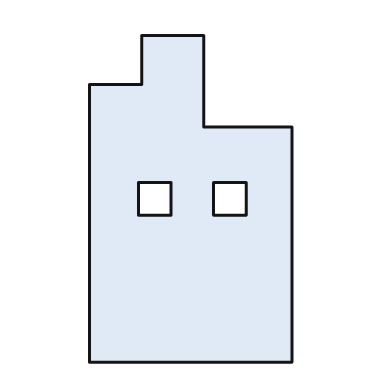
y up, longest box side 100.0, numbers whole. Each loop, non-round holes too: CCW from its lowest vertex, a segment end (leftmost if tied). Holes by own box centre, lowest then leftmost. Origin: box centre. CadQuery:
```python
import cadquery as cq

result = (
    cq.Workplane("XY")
    .moveTo(-31.0, -50.0)
    .lineTo(31.0, -50.0)
    .lineTo(31.0, 22.0)
    .lineTo(4.0, 22.0)
    .lineTo(4.0, 50.0)
    .lineTo(-15.0, 50.0)
    .lineTo(-15.0, 35.0)
    .lineTo(-31.0, 35.0)
    .close()
    .moveTo(-16.0, -5.0)
    .lineTo(-6.0, -5.0)
    .lineTo(-6.0, 5.0)
    .lineTo(-16.0, 5.0)
    .close()
    .moveTo(7.0, -5.0)
    .lineTo(17.0, -5.0)
    .lineTo(17.0, 5.0)
    .lineTo(7.0, 5.0)
    .close()
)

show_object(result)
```